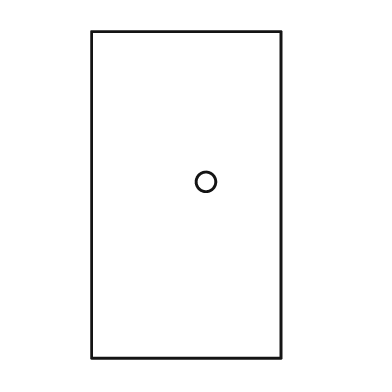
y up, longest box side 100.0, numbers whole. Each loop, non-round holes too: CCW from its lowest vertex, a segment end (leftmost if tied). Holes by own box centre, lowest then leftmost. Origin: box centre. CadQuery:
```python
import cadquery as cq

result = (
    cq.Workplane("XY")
    .moveTo(-29.0, -50.0)
    .lineTo(29.0, -50.0)
    .lineTo(29.0, 50.0)
    .lineTo(-29.0, 50.0)
    .close()
    .moveTo(6.0, 4.0)
    .circle(3.0)
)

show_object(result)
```